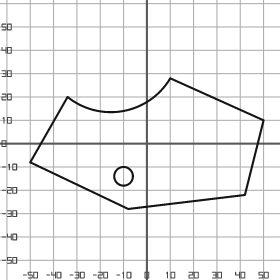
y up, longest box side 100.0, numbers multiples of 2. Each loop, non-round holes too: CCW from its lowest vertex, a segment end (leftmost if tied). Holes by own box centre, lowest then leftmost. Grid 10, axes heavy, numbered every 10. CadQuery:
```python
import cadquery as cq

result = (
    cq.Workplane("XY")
    .moveTo(-8.0, -28.0)
    .lineTo(42.0, -22.0)
    .lineTo(50.0, 10.0)
    .lineTo(10.0, 28.0)
    .threePointArc((-10.0, 14.0), (-34.0, 20.0))
    .lineTo(-50.0, -8.0)
    .close()
    .moveTo(-10.0, -14.0)
    .circle(4.0)
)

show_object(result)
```